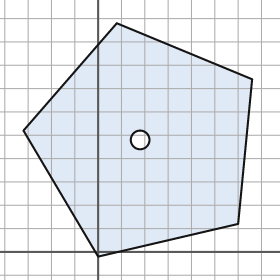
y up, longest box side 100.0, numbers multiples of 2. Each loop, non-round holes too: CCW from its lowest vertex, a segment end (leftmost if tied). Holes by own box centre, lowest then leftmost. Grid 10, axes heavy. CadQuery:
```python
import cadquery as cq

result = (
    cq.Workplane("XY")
    .moveTo(0.0, -2.0)
    .lineTo(60.0, 12.0)
    .lineTo(66.0, 74.0)
    .lineTo(8.0, 98.0)
    .lineTo(-32.0, 52.0)
    .close()
    .moveTo(18.0, 48.0)
    .circle(4.0)
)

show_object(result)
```